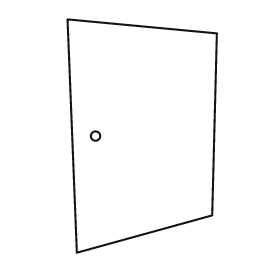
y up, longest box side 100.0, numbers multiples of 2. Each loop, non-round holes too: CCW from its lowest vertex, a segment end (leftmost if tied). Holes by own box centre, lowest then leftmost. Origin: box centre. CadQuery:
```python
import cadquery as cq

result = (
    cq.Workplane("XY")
    .moveTo(-28.0, -50.0)
    .lineTo(30.0, -34.0)
    .lineTo(32.0, 44.0)
    .lineTo(-32.0, 50.0)
    .close()
    .moveTo(-20.0, 0.0)
    .circle(2.0)
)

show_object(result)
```